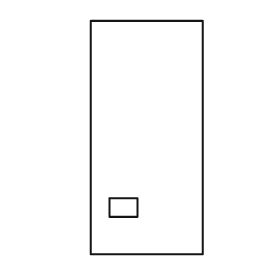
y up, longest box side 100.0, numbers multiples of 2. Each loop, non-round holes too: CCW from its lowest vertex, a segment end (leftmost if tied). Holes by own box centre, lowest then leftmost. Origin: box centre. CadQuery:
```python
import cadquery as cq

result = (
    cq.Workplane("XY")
    .moveTo(-24.0, -50.0)
    .lineTo(24.0, -50.0)
    .lineTo(24.0, 50.0)
    .lineTo(-24.0, 50.0)
    .close()
    .moveTo(-16.0, -34.0)
    .lineTo(-4.0, -34.0)
    .lineTo(-4.0, -26.0)
    .lineTo(-16.0, -26.0)
    .close()
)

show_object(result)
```